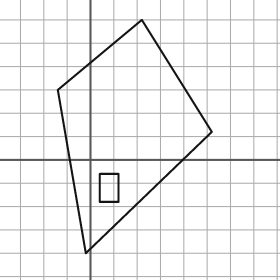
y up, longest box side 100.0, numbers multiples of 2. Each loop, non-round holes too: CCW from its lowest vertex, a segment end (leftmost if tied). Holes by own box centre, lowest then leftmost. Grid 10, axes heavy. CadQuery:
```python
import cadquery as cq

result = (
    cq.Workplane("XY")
    .moveTo(-2.0, -40.0)
    .lineTo(52.0, 12.0)
    .lineTo(22.0, 60.0)
    .lineTo(-14.0, 30.0)
    .close()
    .moveTo(4.0, -18.0)
    .lineTo(12.0, -18.0)
    .lineTo(12.0, -6.0)
    .lineTo(4.0, -6.0)
    .close()
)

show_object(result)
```